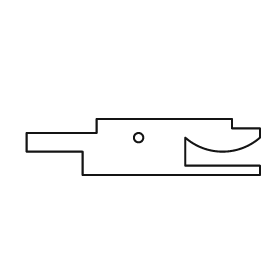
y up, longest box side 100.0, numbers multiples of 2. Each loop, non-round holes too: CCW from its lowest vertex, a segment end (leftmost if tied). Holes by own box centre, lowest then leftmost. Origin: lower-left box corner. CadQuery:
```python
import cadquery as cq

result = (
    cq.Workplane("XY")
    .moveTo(24.0, 0.0)
    .lineTo(100.0, 0.0)
    .lineTo(100.0, 4.0)
    .lineTo(68.0, 4.0)
    .lineTo(68.0, 16.0)
    .threePointArc((84.0, 10.0), (100.0, 16.0))
    .lineTo(100.0, 20.0)
    .lineTo(88.0, 20.0)
    .lineTo(88.0, 24.0)
    .lineTo(30.0, 24.0)
    .lineTo(30.0, 18.0)
    .lineTo(0.0, 18.0)
    .lineTo(0.0, 10.0)
    .lineTo(24.0, 10.0)
    .close()
    .moveTo(48.0, 16.0)
    .circle(2.0)
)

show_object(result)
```